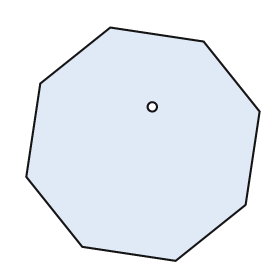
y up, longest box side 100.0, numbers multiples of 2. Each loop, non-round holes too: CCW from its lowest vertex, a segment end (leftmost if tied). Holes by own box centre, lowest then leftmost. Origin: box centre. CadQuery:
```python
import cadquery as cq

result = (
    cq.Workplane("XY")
    .moveTo(14.0, -50.0)
    .lineTo(44.0, -26.0)
    .lineTo(50.0, 14.0)
    .lineTo(26.0, 44.0)
    .lineTo(-14.0, 50.0)
    .lineTo(-44.0, 26.0)
    .lineTo(-50.0, -14.0)
    .lineTo(-26.0, -44.0)
    .close()
    .moveTo(4.0, 16.0)
    .circle(2.0)
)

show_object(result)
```